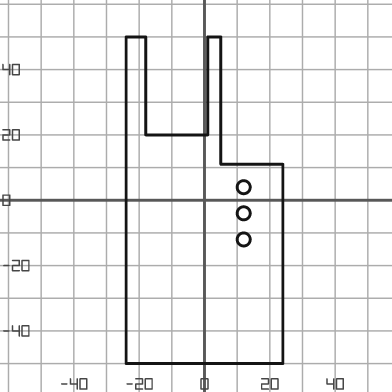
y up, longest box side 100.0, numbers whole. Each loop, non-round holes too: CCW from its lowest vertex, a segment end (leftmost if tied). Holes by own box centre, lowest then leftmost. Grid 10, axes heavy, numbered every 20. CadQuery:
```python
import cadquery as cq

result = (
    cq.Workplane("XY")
    .moveTo(-24.0, -50.0)
    .lineTo(24.0, -50.0)
    .lineTo(24.0, 11.0)
    .lineTo(5.0, 11.0)
    .lineTo(5.0, 50.0)
    .lineTo(1.0, 50.0)
    .lineTo(1.0, 20.0)
    .lineTo(-18.0, 20.0)
    .lineTo(-18.0, 50.0)
    .lineTo(-24.0, 50.0)
    .close()
    .moveTo(12.0, -12.0)
    .circle(2.0)
    .moveTo(12.0, -4.0)
    .circle(2.0)
    .moveTo(12.0, 4.0)
    .circle(2.0)
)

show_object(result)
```